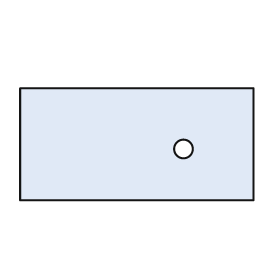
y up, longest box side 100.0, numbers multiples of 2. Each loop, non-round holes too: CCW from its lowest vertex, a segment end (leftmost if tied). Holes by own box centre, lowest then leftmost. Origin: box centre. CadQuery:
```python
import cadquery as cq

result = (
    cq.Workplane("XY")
    .moveTo(-50.0, -24.0)
    .lineTo(50.0, -24.0)
    .lineTo(50.0, 24.0)
    .lineTo(-50.0, 24.0)
    .close()
    .moveTo(20.0, -2.0)
    .circle(4.0)
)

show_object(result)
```